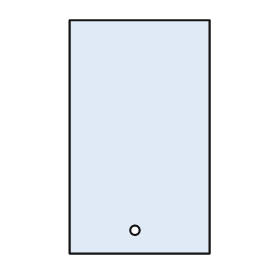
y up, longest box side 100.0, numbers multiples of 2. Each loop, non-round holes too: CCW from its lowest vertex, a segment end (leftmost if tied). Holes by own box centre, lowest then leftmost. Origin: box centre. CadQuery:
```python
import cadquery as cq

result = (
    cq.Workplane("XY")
    .moveTo(-30.0, -50.0)
    .lineTo(30.0, -50.0)
    .lineTo(30.0, 50.0)
    .lineTo(-30.0, 50.0)
    .close()
    .moveTo(-2.0, -40.0)
    .circle(2.0)
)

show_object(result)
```